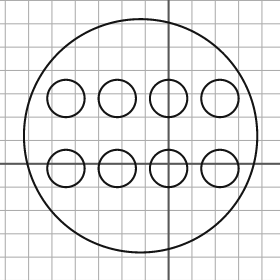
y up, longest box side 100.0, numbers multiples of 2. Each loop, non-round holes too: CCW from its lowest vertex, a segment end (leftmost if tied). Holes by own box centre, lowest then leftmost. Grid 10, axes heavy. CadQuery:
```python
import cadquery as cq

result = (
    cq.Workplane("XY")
    .moveTo(-12.0, 12.0)
    .circle(50.0)
    .moveTo(-44.0, -2.0)
    .circle(8.0)
    .moveTo(-22.0, -2.0)
    .circle(8.0)
    .moveTo(0.0, -2.0)
    .circle(8.0)
    .moveTo(22.0, -2.0)
    .circle(8.0)
    .moveTo(-44.0, 28.0)
    .circle(8.0)
    .moveTo(-22.0, 28.0)
    .circle(8.0)
    .moveTo(0.0, 28.0)
    .circle(8.0)
    .moveTo(22.0, 28.0)
    .circle(8.0)
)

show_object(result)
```